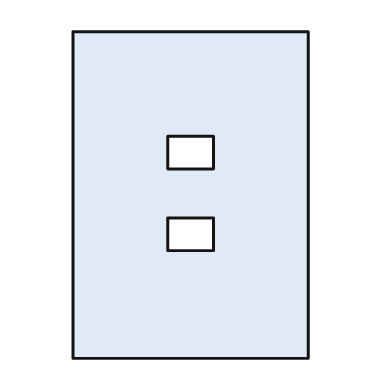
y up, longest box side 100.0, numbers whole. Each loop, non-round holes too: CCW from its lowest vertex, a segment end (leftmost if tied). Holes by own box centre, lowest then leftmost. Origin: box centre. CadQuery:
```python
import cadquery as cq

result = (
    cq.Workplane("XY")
    .moveTo(-36.0, -50.0)
    .lineTo(36.0, -50.0)
    .lineTo(36.0, 50.0)
    .lineTo(-36.0, 50.0)
    .close()
    .moveTo(-7.0, -17.0)
    .lineTo(7.0, -17.0)
    .lineTo(7.0, -7.0)
    .lineTo(-7.0, -7.0)
    .close()
    .moveTo(-7.0, 8.0)
    .lineTo(7.0, 8.0)
    .lineTo(7.0, 18.0)
    .lineTo(-7.0, 18.0)
    .close()
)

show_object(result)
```